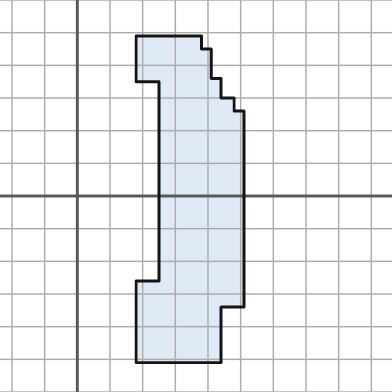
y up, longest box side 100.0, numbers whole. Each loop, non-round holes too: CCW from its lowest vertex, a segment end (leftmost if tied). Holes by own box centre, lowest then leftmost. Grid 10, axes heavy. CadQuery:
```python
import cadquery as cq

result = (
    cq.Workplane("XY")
    .moveTo(18.0, -51.0)
    .lineTo(44.0, -51.0)
    .lineTo(44.0, -34.0)
    .lineTo(51.0, -34.0)
    .lineTo(51.0, 26.0)
    .lineTo(48.0, 26.0)
    .lineTo(48.0, 30.0)
    .lineTo(44.0, 30.0)
    .lineTo(44.0, 36.0)
    .lineTo(41.0, 36.0)
    .lineTo(41.0, 45.0)
    .lineTo(38.0, 45.0)
    .lineTo(38.0, 49.0)
    .lineTo(18.0, 49.0)
    .lineTo(18.0, 35.0)
    .lineTo(25.0, 35.0)
    .lineTo(25.0, -26.0)
    .lineTo(18.0, -26.0)
    .close()
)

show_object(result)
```